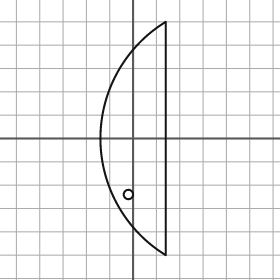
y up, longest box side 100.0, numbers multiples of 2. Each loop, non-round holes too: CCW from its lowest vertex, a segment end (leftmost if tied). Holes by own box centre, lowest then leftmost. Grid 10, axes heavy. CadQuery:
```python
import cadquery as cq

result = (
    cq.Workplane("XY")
    .moveTo(14.0, -50.0)
    .lineTo(14.0, 50.0)
    .threePointArc((-14.0, 0.0), (14.0, -50.0))
    .close()
    .moveTo(-2.0, -24.0)
    .circle(2.0)
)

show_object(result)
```